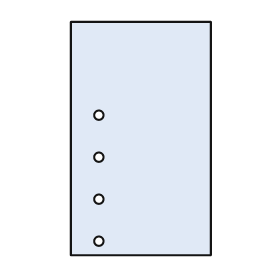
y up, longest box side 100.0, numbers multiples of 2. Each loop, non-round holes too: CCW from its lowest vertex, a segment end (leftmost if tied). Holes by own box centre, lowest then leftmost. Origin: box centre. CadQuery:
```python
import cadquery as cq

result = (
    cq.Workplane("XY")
    .moveTo(-30.0, -50.0)
    .lineTo(30.0, -50.0)
    .lineTo(30.0, 50.0)
    .lineTo(-30.0, 50.0)
    .close()
    .moveTo(-18.0, -44.0)
    .circle(2.0)
    .moveTo(-18.0, -26.0)
    .circle(2.0)
    .moveTo(-18.0, -8.0)
    .circle(2.0)
    .moveTo(-18.0, 10.0)
    .circle(2.0)
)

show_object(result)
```